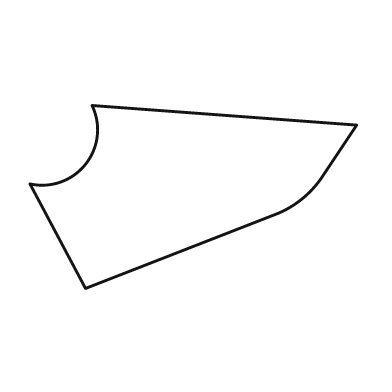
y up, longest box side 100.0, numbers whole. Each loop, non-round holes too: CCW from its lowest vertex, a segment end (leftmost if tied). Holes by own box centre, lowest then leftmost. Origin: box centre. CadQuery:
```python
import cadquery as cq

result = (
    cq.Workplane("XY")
    .moveTo(-33.0, -28.0)
    .lineTo(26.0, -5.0)
    .threePointArc((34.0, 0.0), (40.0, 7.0))
    .lineTo(50.0, 22.0)
    .lineTo(-31.0, 28.0)
    .threePointArc((-33.0, 10.0), (-50.0, 4.0))
    .close()
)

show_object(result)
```